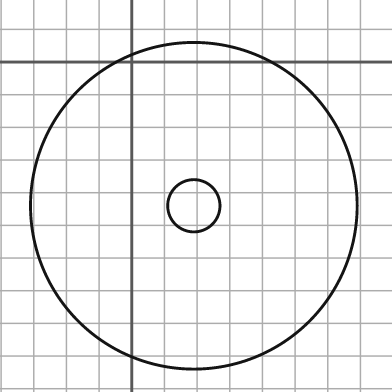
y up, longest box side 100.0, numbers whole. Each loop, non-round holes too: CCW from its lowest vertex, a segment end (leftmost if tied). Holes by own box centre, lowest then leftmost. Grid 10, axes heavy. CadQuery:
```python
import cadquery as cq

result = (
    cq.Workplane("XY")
    .moveTo(19.0, -44.0)
    .circle(50.0)
    .moveTo(19.0, -44.0)
    .circle(8.0)
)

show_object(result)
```